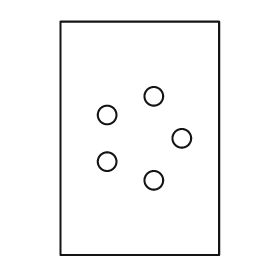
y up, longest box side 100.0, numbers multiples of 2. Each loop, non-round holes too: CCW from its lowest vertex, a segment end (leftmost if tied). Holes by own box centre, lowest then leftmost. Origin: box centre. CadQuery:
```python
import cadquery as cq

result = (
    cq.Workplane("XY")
    .moveTo(-34.0, -50.0)
    .lineTo(34.0, -50.0)
    .lineTo(34.0, 50.0)
    .lineTo(-34.0, 50.0)
    .close()
    .moveTo(6.0, -18.0)
    .circle(4.0)
    .moveTo(-14.0, -10.0)
    .circle(4.0)
    .moveTo(18.0, 0.0)
    .circle(4.0)
    .moveTo(-14.0, 10.0)
    .circle(4.0)
    .moveTo(6.0, 18.0)
    .circle(4.0)
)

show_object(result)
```